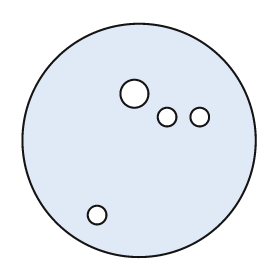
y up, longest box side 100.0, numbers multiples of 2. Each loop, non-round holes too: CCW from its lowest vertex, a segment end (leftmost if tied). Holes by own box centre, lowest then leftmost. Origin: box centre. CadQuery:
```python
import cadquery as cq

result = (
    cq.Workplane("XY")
    .moveTo(0.0, 0.0)
    .circle(50.0)
    .moveTo(-18.0, -32.0)
    .circle(4.0)
    .moveTo(12.0, 10.0)
    .circle(4.0)
    .moveTo(26.0, 10.0)
    .circle(4.0)
    .moveTo(-2.0, 20.0)
    .circle(6.0)
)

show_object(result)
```